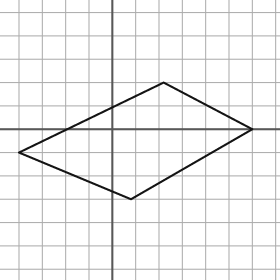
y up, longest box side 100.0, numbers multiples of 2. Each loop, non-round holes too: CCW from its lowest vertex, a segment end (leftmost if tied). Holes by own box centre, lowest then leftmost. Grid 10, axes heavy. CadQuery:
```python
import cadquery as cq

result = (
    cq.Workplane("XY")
    .moveTo(8.0, -30.0)
    .lineTo(60.0, 0.0)
    .lineTo(22.0, 20.0)
    .lineTo(-40.0, -10.0)
    .close()
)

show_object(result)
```